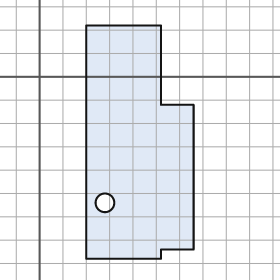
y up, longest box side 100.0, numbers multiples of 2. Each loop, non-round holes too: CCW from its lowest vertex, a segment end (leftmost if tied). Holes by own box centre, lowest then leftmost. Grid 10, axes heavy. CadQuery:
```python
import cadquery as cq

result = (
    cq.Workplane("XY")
    .moveTo(20.0, -78.0)
    .lineTo(52.0, -78.0)
    .lineTo(52.0, -74.0)
    .lineTo(66.0, -74.0)
    .lineTo(66.0, -12.0)
    .lineTo(52.0, -12.0)
    .lineTo(52.0, 22.0)
    .lineTo(20.0, 22.0)
    .close()
    .moveTo(28.0, -54.0)
    .circle(4.0)
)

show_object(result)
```